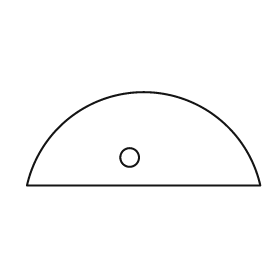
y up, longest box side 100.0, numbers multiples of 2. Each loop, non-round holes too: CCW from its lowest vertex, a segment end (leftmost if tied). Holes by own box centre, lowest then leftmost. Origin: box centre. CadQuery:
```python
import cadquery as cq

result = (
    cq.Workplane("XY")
    .moveTo(-50.0, -20.0)
    .lineTo(50.0, -20.0)
    .threePointArc((0.0, 20.0), (-50.0, -20.0))
    .close()
    .moveTo(-6.0, -8.0)
    .circle(4.0)
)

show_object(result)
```